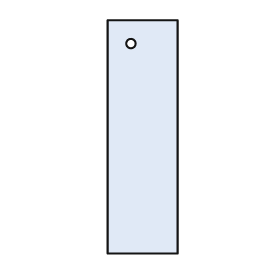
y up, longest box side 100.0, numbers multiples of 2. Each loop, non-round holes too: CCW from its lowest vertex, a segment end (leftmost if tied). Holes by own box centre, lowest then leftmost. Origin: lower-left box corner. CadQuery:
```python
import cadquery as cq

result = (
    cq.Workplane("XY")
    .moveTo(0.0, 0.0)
    .lineTo(30.0, 0.0)
    .lineTo(30.0, 100.0)
    .lineTo(0.0, 100.0)
    .close()
    .moveTo(10.0, 90.0)
    .circle(2.0)
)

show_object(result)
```